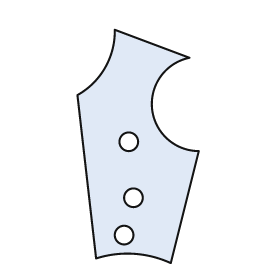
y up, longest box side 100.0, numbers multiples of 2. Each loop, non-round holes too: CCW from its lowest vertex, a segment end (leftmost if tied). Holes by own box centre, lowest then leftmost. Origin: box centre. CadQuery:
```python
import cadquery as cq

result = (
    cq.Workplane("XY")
    .moveTo(14.0, -50.0)
    .lineTo(26.0, -2.0)
    .threePointArc((6.0, 16.0), (22.0, 38.0))
    .lineTo(-10.0, 50.0)
    .threePointArc((-14.0, 34.0), (-26.0, 22.0))
    .lineTo(-18.0, -48.0)
    .threePointArc((-2.0, -46.0), (14.0, -50.0))
    .close()
    .moveTo(-6.0, -38.0)
    .circle(4.0)
    .moveTo(-2.0, -22.0)
    .circle(4.0)
    .moveTo(-4.0, 2.0)
    .circle(4.0)
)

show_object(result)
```